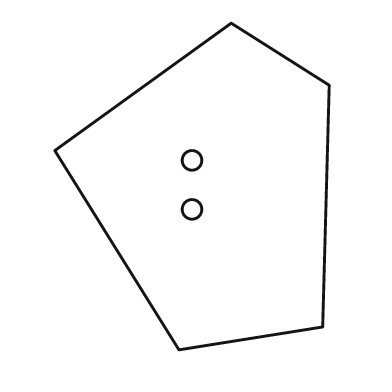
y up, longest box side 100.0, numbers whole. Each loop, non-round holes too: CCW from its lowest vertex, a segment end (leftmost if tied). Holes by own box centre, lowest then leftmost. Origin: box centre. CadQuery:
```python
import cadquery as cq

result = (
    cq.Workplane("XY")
    .moveTo(-4.0, -50.0)
    .lineTo(40.0, -43.0)
    .lineTo(42.0, 31.0)
    .lineTo(12.0, 50.0)
    .lineTo(-42.0, 11.0)
    .close()
    .moveTo(0.0, -7.0)
    .circle(3.0)
    .moveTo(0.0, 8.0)
    .circle(3.0)
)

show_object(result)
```